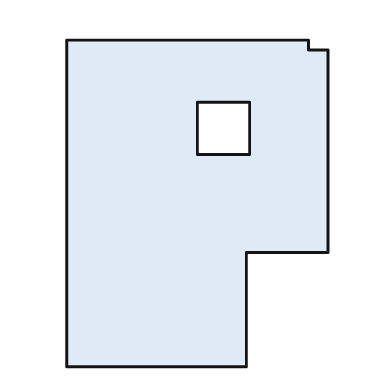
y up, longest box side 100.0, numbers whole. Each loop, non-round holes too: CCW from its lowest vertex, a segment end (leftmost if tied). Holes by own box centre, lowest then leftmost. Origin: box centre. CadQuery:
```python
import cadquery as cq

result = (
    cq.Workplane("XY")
    .moveTo(-40.0, -50.0)
    .lineTo(15.0, -50.0)
    .lineTo(15.0, -15.0)
    .lineTo(40.0, -15.0)
    .lineTo(40.0, 47.0)
    .lineTo(34.0, 47.0)
    .lineTo(34.0, 50.0)
    .lineTo(-40.0, 50.0)
    .close()
    .moveTo(0.0, 15.0)
    .lineTo(16.0, 15.0)
    .lineTo(16.0, 31.0)
    .lineTo(0.0, 31.0)
    .close()
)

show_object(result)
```